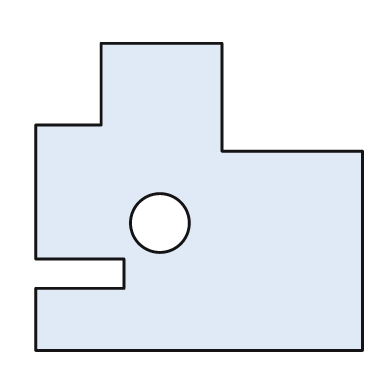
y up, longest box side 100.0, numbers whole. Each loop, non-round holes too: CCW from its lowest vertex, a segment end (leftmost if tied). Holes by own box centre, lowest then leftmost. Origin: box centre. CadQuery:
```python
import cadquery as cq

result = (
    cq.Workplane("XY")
    .moveTo(-50.0, -47.0)
    .lineTo(50.0, -47.0)
    .lineTo(50.0, 14.0)
    .lineTo(7.0, 14.0)
    .lineTo(7.0, 47.0)
    .lineTo(-30.0, 47.0)
    .lineTo(-30.0, 22.0)
    .lineTo(-50.0, 22.0)
    .lineTo(-50.0, -19.0)
    .lineTo(-23.0, -19.0)
    .lineTo(-23.0, -28.0)
    .lineTo(-50.0, -28.0)
    .close()
    .moveTo(-12.0, -8.0)
    .circle(9.0)
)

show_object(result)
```